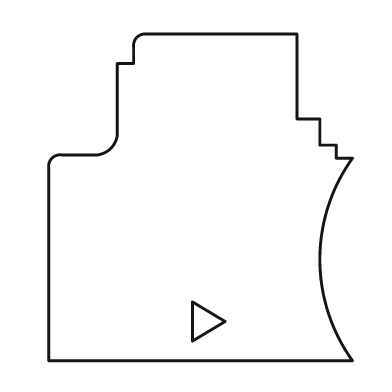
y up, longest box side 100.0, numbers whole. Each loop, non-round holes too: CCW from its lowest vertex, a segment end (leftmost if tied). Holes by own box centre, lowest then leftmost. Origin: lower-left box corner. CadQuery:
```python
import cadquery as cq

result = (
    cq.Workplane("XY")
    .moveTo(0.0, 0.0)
    .lineTo(93.0, 0.0)
    .threePointArc((83.0, 31.0), (93.0, 62.0))
    .lineTo(88.0, 62.0)
    .lineTo(88.0, 66.0)
    .lineTo(83.0, 66.0)
    .lineTo(83.0, 74.0)
    .lineTo(76.0, 74.0)
    .lineTo(76.0, 100.0)
    .lineTo(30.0, 100.0)
    .threePointArc((27.0, 99.0), (26.0, 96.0))
    .lineTo(26.0, 91.0)
    .lineTo(21.0, 91.0)
    .lineTo(21.0, 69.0)
    .threePointArc((19.0, 65.0), (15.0, 63.0))
    .lineTo(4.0, 63.0)
    .threePointArc((1.0, 62.0), (0.0, 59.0))
    .close()
    .moveTo(44.0, 6.0)
    .lineTo(54.0, 12.0)
    .lineTo(44.0, 18.0)
    .close()
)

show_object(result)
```